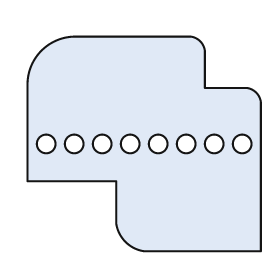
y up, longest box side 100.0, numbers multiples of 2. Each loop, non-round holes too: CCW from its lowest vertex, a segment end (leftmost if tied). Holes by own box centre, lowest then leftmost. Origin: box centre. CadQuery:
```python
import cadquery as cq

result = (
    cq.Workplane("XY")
    .moveTo(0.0, -46.0)
    .lineTo(50.0, -46.0)
    .lineTo(50.0, 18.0)
    .threePointArc((48.0, 22.0), (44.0, 24.0))
    .lineTo(26.0, 24.0)
    .lineTo(26.0, 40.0)
    .threePointArc((24.0, 44.0), (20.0, 46.0))
    .lineTo(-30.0, 46.0)
    .threePointArc((-44.0, 40.0), (-50.0, 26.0))
    .lineTo(-50.0, -16.0)
    .lineTo(-12.0, -16.0)
    .lineTo(-12.0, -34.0)
    .threePointArc((-8.0, -42.0), (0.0, -46.0))
    .close()
    .moveTo(-42.0, 0.0)
    .circle(4.0)
    .moveTo(-30.0, 0.0)
    .circle(4.0)
    .moveTo(-18.0, 0.0)
    .circle(4.0)
    .moveTo(-6.0, 0.0)
    .circle(4.0)
    .moveTo(6.0, 0.0)
    .circle(4.0)
    .moveTo(18.0, 0.0)
    .circle(4.0)
    .moveTo(30.0, 0.0)
    .circle(4.0)
    .moveTo(42.0, 0.0)
    .circle(4.0)
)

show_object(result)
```